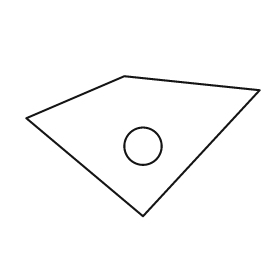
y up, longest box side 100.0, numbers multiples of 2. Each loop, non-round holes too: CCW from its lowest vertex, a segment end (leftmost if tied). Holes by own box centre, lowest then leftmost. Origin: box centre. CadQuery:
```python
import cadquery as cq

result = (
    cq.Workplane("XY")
    .moveTo(0.0, -30.0)
    .lineTo(50.0, 24.0)
    .lineTo(-8.0, 30.0)
    .lineTo(-50.0, 12.0)
    .close()
    .moveTo(0.0, 0.0)
    .circle(8.0)
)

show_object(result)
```